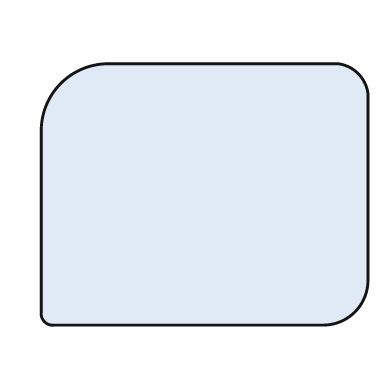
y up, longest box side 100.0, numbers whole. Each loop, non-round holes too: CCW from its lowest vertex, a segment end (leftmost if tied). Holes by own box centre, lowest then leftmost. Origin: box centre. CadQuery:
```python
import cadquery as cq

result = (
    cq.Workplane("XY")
    .moveTo(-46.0, -40.0)
    .lineTo(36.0, -40.0)
    .threePointArc((46.0, -36.0), (50.0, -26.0))
    .lineTo(50.0, 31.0)
    .threePointArc((47.0, 37.0), (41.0, 40.0))
    .lineTo(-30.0, 40.0)
    .threePointArc((-44.0, 34.0), (-50.0, 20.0))
    .lineTo(-50.0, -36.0)
    .threePointArc((-49.0, -39.0), (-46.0, -40.0))
    .close()
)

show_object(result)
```